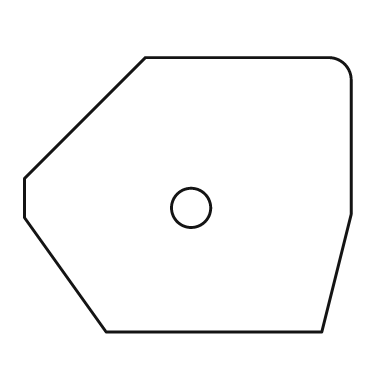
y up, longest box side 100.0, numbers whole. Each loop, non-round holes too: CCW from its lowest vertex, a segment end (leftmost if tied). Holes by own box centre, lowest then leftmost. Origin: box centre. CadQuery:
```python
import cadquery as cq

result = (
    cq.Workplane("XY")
    .moveTo(-25.0, -42.0)
    .lineTo(41.0, -42.0)
    .lineTo(50.0, -6.0)
    .lineTo(50.0, 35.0)
    .threePointArc((48.0, 40.0), (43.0, 42.0))
    .lineTo(-13.0, 42.0)
    .lineTo(-50.0, 5.0)
    .lineTo(-50.0, -7.0)
    .close()
    .moveTo(1.0, -4.0)
    .circle(6.0)
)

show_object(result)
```